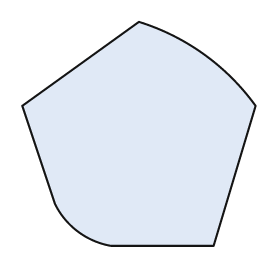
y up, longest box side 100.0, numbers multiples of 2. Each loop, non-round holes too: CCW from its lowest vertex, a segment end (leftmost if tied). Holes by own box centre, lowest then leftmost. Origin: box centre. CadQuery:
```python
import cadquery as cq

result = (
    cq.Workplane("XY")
    .moveTo(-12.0, -48.0)
    .lineTo(32.0, -48.0)
    .lineTo(50.0, 12.0)
    .threePointArc((28.0, 34.0), (0.0, 48.0))
    .lineTo(-50.0, 12.0)
    .lineTo(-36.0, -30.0)
    .threePointArc((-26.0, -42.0), (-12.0, -48.0))
    .close()
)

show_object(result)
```